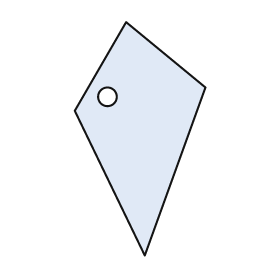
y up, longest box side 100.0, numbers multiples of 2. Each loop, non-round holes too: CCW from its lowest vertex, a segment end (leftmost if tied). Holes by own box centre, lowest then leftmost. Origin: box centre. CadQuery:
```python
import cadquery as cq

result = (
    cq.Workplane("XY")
    .moveTo(2.0, -50.0)
    .lineTo(28.0, 22.0)
    .lineTo(-6.0, 50.0)
    .lineTo(-28.0, 12.0)
    .close()
    .moveTo(-14.0, 18.0)
    .circle(4.0)
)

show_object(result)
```